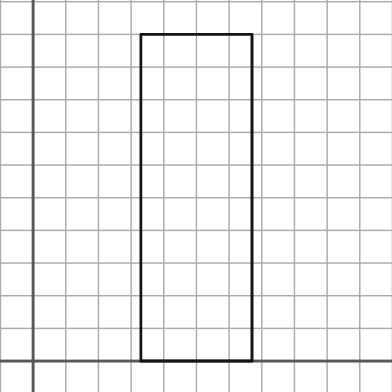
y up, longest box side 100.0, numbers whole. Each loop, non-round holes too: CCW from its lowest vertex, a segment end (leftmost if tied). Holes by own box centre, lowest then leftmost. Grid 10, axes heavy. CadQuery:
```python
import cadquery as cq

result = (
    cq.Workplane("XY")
    .moveTo(33.0, 0.0)
    .lineTo(67.0, 0.0)
    .lineTo(67.0, 100.0)
    .lineTo(33.0, 100.0)
    .close()
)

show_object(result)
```